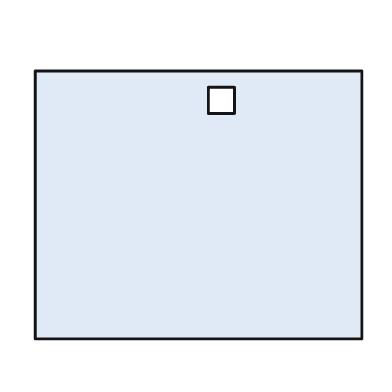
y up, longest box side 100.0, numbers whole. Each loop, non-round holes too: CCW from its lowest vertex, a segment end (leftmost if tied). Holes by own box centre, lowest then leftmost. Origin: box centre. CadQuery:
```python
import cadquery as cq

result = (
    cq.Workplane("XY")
    .moveTo(-50.0, -41.0)
    .lineTo(50.0, -41.0)
    .lineTo(50.0, 41.0)
    .lineTo(-50.0, 41.0)
    .close()
    .moveTo(3.0, 28.0)
    .lineTo(11.0, 28.0)
    .lineTo(11.0, 36.0)
    .lineTo(3.0, 36.0)
    .close()
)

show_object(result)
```